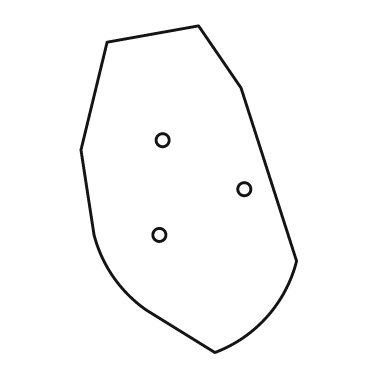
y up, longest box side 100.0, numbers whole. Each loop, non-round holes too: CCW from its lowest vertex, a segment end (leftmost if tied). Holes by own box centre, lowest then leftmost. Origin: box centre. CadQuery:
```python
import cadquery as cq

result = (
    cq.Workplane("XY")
    .moveTo(8.0, -50.0)
    .threePointArc((24.0, -39.0), (33.0, -22.0))
    .lineTo(16.0, 31.0)
    .lineTo(3.0, 50.0)
    .lineTo(-25.0, 45.0)
    .lineTo(-33.0, 12.0)
    .lineTo(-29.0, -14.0)
    .threePointArc((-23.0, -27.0), (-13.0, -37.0))
    .close()
    .moveTo(-9.0, -14.0)
    .circle(2.0)
    .moveTo(17.0, 0.0)
    .circle(2.0)
    .moveTo(-8.0, 15.0)
    .circle(2.0)
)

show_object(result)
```